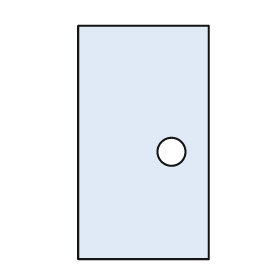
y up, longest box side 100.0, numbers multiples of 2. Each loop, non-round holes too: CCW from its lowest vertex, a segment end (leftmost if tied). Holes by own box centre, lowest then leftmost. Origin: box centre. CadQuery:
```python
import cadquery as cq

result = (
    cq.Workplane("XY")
    .moveTo(-28.0, -50.0)
    .lineTo(28.0, -50.0)
    .lineTo(28.0, 50.0)
    .lineTo(-28.0, 50.0)
    .close()
    .moveTo(12.0, -4.0)
    .circle(6.0)
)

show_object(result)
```